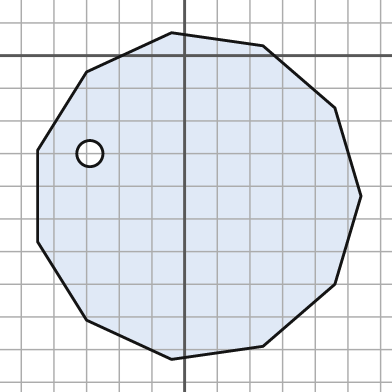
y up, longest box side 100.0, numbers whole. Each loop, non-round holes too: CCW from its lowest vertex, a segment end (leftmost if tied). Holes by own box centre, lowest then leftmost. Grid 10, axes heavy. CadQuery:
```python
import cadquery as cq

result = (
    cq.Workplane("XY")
    .moveTo(-4.0, -93.0)
    .lineTo(24.0, -89.0)
    .lineTo(46.0, -70.0)
    .lineTo(54.0, -43.0)
    .lineTo(46.0, -16.0)
    .lineTo(24.0, 3.0)
    .lineTo(-4.0, 7.0)
    .lineTo(-30.0, -5.0)
    .lineTo(-45.0, -29.0)
    .lineTo(-45.0, -57.0)
    .lineTo(-30.0, -81.0)
    .close()
    .moveTo(-29.0, -30.0)
    .circle(4.0)
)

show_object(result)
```